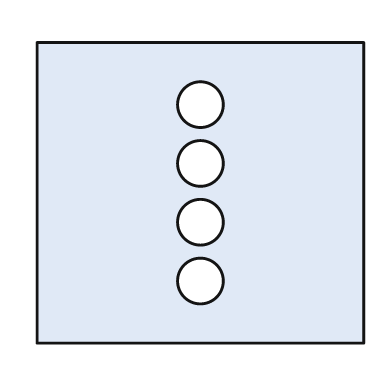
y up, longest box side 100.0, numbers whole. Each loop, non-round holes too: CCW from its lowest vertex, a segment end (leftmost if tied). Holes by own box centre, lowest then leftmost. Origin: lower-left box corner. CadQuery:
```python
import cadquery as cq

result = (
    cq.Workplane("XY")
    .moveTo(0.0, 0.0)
    .lineTo(100.0, 0.0)
    .lineTo(100.0, 92.0)
    .lineTo(0.0, 92.0)
    .close()
    .moveTo(50.0, 19.0)
    .circle(7.0)
    .moveTo(50.0, 37.0)
    .circle(7.0)
    .moveTo(50.0, 55.0)
    .circle(7.0)
    .moveTo(50.0, 73.0)
    .circle(7.0)
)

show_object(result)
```